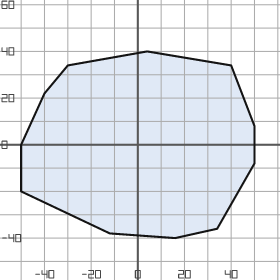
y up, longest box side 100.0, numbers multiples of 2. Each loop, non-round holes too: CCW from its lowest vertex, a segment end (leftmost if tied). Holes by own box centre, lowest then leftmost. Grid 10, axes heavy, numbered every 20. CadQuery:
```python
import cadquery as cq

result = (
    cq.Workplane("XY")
    .moveTo(16.0, -40.0)
    .lineTo(34.0, -36.0)
    .lineTo(50.0, -8.0)
    .lineTo(50.0, 8.0)
    .lineTo(40.0, 34.0)
    .lineTo(4.0, 40.0)
    .lineTo(-30.0, 34.0)
    .lineTo(-40.0, 22.0)
    .lineTo(-50.0, 0.0)
    .lineTo(-50.0, -20.0)
    .lineTo(-12.0, -38.0)
    .close()
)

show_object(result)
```